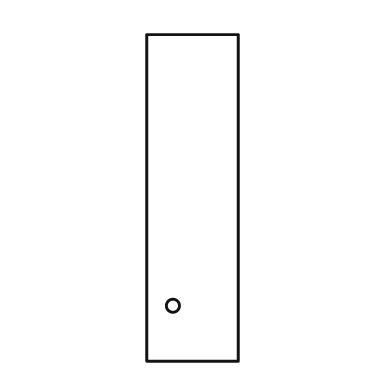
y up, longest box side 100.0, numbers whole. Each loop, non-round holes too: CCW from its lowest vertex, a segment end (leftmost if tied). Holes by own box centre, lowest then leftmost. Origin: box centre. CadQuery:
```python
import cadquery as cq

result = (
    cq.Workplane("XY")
    .moveTo(-14.0, -50.0)
    .lineTo(14.0, -50.0)
    .lineTo(14.0, 50.0)
    .lineTo(-14.0, 50.0)
    .close()
    .moveTo(-6.0, -33.0)
    .circle(2.0)
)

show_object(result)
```